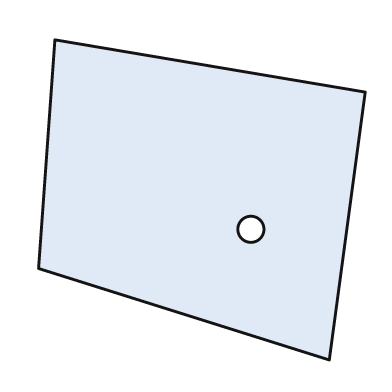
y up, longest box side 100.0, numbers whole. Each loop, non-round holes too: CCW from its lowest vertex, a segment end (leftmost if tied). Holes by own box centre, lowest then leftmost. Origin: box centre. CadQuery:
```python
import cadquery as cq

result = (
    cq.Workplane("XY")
    .moveTo(39.0, -49.0)
    .lineTo(50.0, 33.0)
    .lineTo(-45.0, 49.0)
    .lineTo(-50.0, -21.0)
    .close()
    .moveTo(15.0, -9.0)
    .circle(4.0)
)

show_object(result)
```